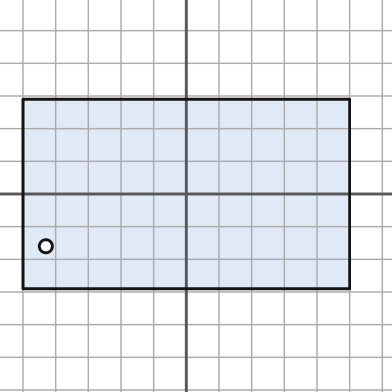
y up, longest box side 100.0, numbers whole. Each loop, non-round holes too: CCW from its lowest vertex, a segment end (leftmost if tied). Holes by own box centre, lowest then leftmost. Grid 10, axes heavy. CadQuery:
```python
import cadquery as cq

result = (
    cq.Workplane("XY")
    .moveTo(-50.0, -29.0)
    .lineTo(50.0, -29.0)
    .lineTo(50.0, 29.0)
    .lineTo(-50.0, 29.0)
    .close()
    .moveTo(-43.0, -16.0)
    .circle(2.0)
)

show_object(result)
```